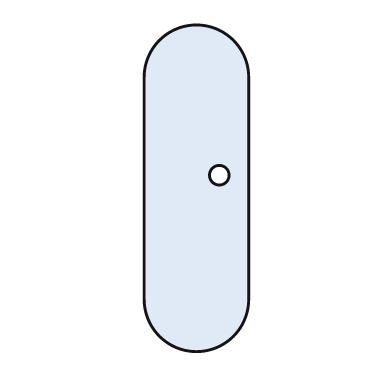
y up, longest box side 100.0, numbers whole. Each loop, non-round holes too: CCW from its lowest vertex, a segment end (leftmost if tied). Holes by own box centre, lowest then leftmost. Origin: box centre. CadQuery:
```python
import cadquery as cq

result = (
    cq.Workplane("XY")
    .moveTo(-16.0, -34.0)
    .threePointArc((0.0, -50.0), (16.0, -34.0))
    .lineTo(16.0, 34.0)
    .threePointArc((0.0, 50.0), (-16.0, 34.0))
    .close()
    .moveTo(7.0, 4.0)
    .circle(3.0)
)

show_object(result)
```